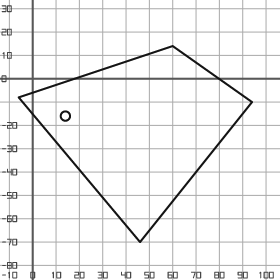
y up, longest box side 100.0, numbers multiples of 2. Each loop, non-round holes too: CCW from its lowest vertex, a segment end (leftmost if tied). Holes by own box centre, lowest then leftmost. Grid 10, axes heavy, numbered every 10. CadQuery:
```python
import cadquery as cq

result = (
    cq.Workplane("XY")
    .moveTo(46.0, -70.0)
    .lineTo(94.0, -10.0)
    .lineTo(60.0, 14.0)
    .lineTo(-6.0, -8.0)
    .close()
    .moveTo(14.0, -16.0)
    .circle(2.0)
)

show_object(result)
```